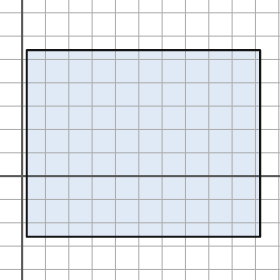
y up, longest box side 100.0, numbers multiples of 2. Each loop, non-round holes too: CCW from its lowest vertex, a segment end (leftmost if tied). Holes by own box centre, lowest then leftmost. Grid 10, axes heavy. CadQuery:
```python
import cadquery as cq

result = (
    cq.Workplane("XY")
    .moveTo(2.0, -26.0)
    .lineTo(102.0, -26.0)
    .lineTo(102.0, 54.0)
    .lineTo(2.0, 54.0)
    .close()
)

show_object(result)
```